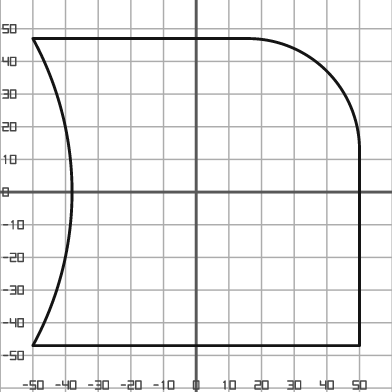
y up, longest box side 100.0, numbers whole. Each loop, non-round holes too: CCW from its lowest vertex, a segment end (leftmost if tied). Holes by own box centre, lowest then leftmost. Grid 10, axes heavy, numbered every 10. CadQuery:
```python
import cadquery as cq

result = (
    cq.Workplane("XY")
    .moveTo(-50.0, -47.0)
    .lineTo(50.0, -47.0)
    .lineTo(50.0, 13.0)
    .threePointArc((40.0, 37.0), (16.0, 47.0))
    .lineTo(-50.0, 47.0)
    .threePointArc((-38.0, 0.0), (-50.0, -47.0))
    .close()
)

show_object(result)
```